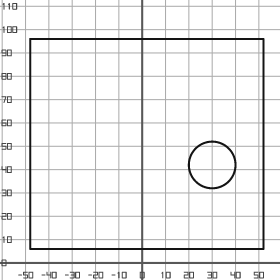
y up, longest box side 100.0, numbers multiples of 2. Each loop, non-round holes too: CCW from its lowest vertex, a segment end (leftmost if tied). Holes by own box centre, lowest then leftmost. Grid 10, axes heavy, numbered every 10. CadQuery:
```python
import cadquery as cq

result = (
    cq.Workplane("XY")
    .moveTo(-48.0, 6.0)
    .lineTo(52.0, 6.0)
    .lineTo(52.0, 96.0)
    .lineTo(-48.0, 96.0)
    .close()
    .moveTo(30.0, 42.0)
    .circle(10.0)
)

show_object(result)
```